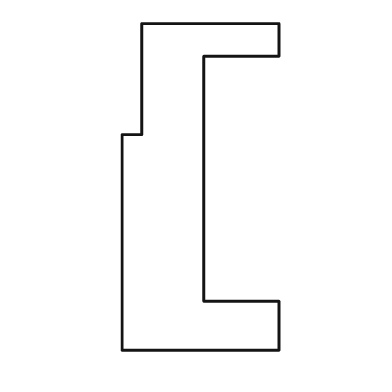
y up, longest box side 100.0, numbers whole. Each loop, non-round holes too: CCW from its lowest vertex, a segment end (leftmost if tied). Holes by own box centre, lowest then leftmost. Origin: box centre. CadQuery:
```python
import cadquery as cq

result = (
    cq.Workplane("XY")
    .moveTo(-24.0, -50.0)
    .lineTo(24.0, -50.0)
    .lineTo(24.0, -35.0)
    .lineTo(1.0, -35.0)
    .lineTo(1.0, 40.0)
    .lineTo(24.0, 40.0)
    .lineTo(24.0, 50.0)
    .lineTo(-18.0, 50.0)
    .lineTo(-18.0, 16.0)
    .lineTo(-24.0, 16.0)
    .close()
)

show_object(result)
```